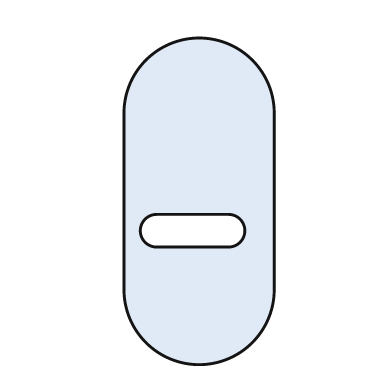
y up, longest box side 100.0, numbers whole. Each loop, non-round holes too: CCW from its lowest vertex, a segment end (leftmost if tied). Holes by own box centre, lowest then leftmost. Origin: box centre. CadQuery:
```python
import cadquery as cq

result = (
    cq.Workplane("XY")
    .moveTo(-23.0, -27.0)
    .threePointArc((0.0, -50.0), (23.0, -27.0))
    .lineTo(23.0, 27.0)
    .threePointArc((0.0, 50.0), (-23.0, 27.0))
    .close()
    .moveTo(-13.0, -14.0)
    .lineTo(9.0, -14.0)
    .threePointArc((14.0, -9.0), (9.0, -4.0))
    .lineTo(-13.0, -4.0)
    .threePointArc((-18.0, -9.0), (-13.0, -14.0))
    .close()
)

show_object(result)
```